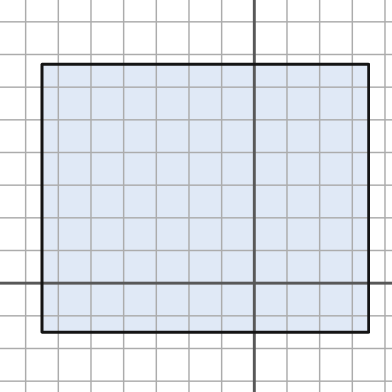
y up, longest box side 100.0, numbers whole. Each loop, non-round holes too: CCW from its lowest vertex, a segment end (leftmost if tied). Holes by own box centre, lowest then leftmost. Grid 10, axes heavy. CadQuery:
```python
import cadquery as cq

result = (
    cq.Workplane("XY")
    .moveTo(-65.0, -15.0)
    .lineTo(35.0, -15.0)
    .lineTo(35.0, 67.0)
    .lineTo(-65.0, 67.0)
    .close()
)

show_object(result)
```